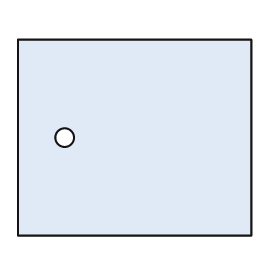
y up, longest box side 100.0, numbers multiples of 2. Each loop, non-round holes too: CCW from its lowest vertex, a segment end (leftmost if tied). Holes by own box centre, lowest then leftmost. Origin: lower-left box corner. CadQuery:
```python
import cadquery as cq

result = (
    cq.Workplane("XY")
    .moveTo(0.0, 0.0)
    .lineTo(100.0, 0.0)
    .lineTo(100.0, 84.0)
    .lineTo(0.0, 84.0)
    .close()
    .moveTo(20.0, 42.0)
    .circle(4.0)
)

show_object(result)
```